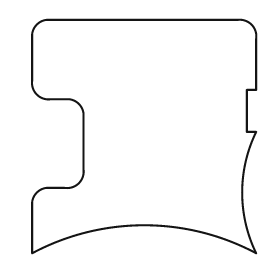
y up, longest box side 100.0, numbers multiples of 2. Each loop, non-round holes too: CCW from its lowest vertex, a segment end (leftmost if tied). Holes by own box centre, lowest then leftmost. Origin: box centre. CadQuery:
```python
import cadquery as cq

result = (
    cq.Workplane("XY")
    .moveTo(-48.0, -50.0)
    .threePointArc((0.0, -38.0), (48.0, -50.0))
    .threePointArc((42.0, -24.0), (48.0, 2.0))
    .lineTo(44.0, 2.0)
    .lineTo(44.0, 20.0)
    .lineTo(48.0, 20.0)
    .lineTo(48.0, 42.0)
    .threePointArc((46.0, 48.0), (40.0, 50.0))
    .lineTo(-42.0, 50.0)
    .threePointArc((-46.0, 48.0), (-48.0, 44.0))
    .lineTo(-48.0, 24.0)
    .threePointArc((-46.0, 18.0), (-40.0, 16.0))
    .lineTo(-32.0, 16.0)
    .threePointArc((-28.0, 14.0), (-26.0, 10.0))
    .lineTo(-26.0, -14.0)
    .threePointArc((-28.0, -20.0), (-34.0, -22.0))
    .lineTo(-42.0, -22.0)
    .threePointArc((-46.0, -24.0), (-48.0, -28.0))
    .close()
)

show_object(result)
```